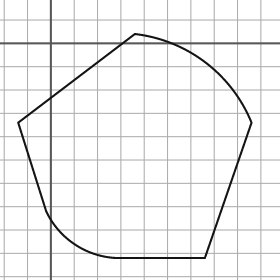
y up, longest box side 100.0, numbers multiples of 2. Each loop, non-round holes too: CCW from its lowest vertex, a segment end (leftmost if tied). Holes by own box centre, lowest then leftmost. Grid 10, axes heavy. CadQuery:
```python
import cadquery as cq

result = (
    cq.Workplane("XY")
    .moveTo(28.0, -92.0)
    .lineTo(66.0, -92.0)
    .lineTo(86.0, -34.0)
    .threePointArc((66.0, -8.0), (36.0, 4.0))
    .lineTo(-14.0, -34.0)
    .lineTo(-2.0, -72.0)
    .threePointArc((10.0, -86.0), (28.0, -92.0))
    .close()
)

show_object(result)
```